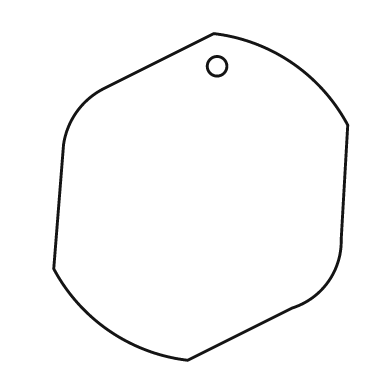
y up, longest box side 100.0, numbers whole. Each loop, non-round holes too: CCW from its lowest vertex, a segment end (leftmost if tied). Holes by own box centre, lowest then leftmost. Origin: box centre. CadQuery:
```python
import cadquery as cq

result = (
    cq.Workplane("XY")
    .moveTo(-4.0, -50.0)
    .lineTo(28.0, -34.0)
    .threePointArc((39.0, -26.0), (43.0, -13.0))
    .lineTo(45.0, 22.0)
    .threePointArc((28.0, 41.0), (4.0, 50.0))
    .lineTo(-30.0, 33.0)
    .threePointArc((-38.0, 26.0), (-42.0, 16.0))
    .lineTo(-45.0, -22.0)
    .threePointArc((-28.0, -41.0), (-4.0, -50.0))
    .close()
    .moveTo(5.0, 40.0)
    .circle(3.0)
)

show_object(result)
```